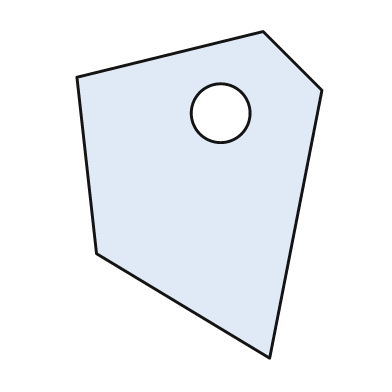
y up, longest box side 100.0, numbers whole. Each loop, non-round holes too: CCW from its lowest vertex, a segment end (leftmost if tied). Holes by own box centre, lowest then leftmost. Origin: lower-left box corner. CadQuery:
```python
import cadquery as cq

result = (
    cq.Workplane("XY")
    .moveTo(59.0, 0.0)
    .lineTo(75.0, 82.0)
    .lineTo(57.0, 100.0)
    .lineTo(0.0, 86.0)
    .lineTo(6.0, 32.0)
    .close()
    .moveTo(44.0, 75.0)
    .circle(9.0)
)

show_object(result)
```